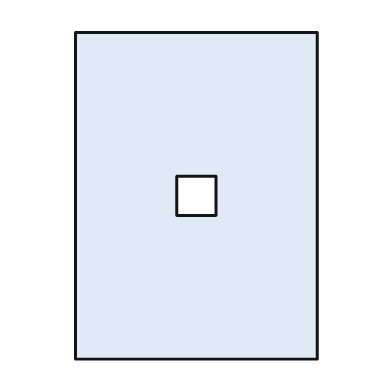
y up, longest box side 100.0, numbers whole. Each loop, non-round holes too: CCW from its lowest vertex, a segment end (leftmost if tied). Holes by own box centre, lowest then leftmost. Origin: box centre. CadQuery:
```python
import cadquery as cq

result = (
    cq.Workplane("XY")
    .moveTo(-37.0, -50.0)
    .lineTo(37.0, -50.0)
    .lineTo(37.0, 50.0)
    .lineTo(-37.0, 50.0)
    .close()
    .moveTo(-6.0, -6.0)
    .lineTo(6.0, -6.0)
    .lineTo(6.0, 6.0)
    .lineTo(-6.0, 6.0)
    .close()
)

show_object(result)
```